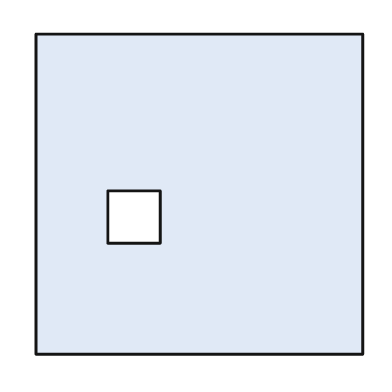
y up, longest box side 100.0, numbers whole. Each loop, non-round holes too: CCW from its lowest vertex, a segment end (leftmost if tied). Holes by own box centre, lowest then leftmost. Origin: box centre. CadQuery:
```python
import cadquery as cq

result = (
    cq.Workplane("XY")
    .moveTo(-50.0, -49.0)
    .lineTo(50.0, -49.0)
    .lineTo(50.0, 49.0)
    .lineTo(-50.0, 49.0)
    .close()
    .moveTo(-28.0, -15.0)
    .lineTo(-12.0, -15.0)
    .lineTo(-12.0, 1.0)
    .lineTo(-28.0, 1.0)
    .close()
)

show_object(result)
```